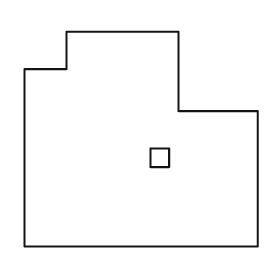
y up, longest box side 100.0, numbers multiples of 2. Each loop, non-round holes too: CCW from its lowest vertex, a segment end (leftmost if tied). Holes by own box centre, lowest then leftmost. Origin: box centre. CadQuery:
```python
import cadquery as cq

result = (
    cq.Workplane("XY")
    .moveTo(-50.0, -46.0)
    .lineTo(50.0, -46.0)
    .lineTo(50.0, 12.0)
    .lineTo(16.0, 12.0)
    .lineTo(16.0, 46.0)
    .lineTo(-32.0, 46.0)
    .lineTo(-32.0, 30.0)
    .lineTo(-50.0, 30.0)
    .close()
    .moveTo(4.0, -12.0)
    .lineTo(12.0, -12.0)
    .lineTo(12.0, -4.0)
    .lineTo(4.0, -4.0)
    .close()
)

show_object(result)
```